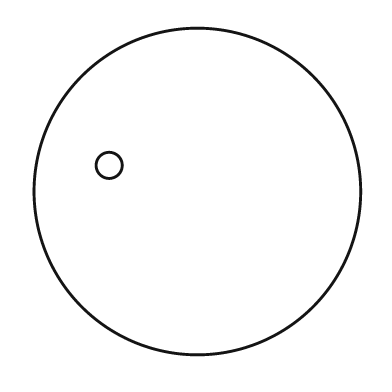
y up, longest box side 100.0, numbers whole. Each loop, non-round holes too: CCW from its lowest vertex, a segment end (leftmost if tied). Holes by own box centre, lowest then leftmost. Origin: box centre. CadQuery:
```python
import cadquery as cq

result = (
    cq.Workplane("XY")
    .moveTo(0.0, 0.0)
    .circle(50.0)
    .moveTo(-27.0, 8.0)
    .circle(4.0)
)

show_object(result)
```